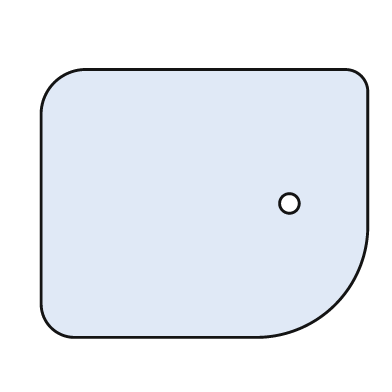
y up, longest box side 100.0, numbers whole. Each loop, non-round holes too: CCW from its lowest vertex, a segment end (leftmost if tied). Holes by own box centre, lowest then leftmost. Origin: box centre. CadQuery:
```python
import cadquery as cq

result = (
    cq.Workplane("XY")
    .moveTo(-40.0, -41.0)
    .lineTo(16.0, -41.0)
    .threePointArc((40.0, -31.0), (50.0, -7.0))
    .lineTo(50.0, 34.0)
    .threePointArc((48.0, 39.0), (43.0, 41.0))
    .lineTo(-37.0, 41.0)
    .threePointArc((-46.0, 37.0), (-50.0, 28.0))
    .lineTo(-50.0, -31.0)
    .threePointArc((-47.0, -38.0), (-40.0, -41.0))
    .close()
    .moveTo(26.0, 0.0)
    .circle(3.0)
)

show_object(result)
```